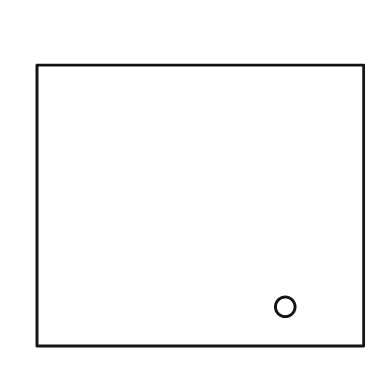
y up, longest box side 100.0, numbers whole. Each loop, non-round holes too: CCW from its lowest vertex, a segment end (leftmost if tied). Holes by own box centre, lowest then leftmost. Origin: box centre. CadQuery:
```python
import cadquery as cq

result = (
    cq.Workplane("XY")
    .moveTo(-50.0, -43.0)
    .lineTo(50.0, -43.0)
    .lineTo(50.0, 43.0)
    .lineTo(-50.0, 43.0)
    .close()
    .moveTo(26.0, -31.0)
    .circle(3.0)
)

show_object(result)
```